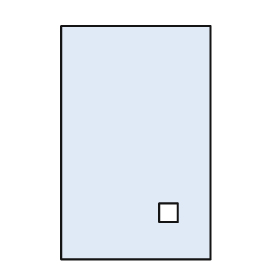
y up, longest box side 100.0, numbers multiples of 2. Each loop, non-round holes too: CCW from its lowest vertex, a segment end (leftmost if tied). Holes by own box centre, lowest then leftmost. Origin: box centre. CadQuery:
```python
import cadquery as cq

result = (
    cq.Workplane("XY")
    .moveTo(-32.0, -50.0)
    .lineTo(32.0, -50.0)
    .lineTo(32.0, 50.0)
    .lineTo(-32.0, 50.0)
    .close()
    .moveTo(10.0, -34.0)
    .lineTo(18.0, -34.0)
    .lineTo(18.0, -26.0)
    .lineTo(10.0, -26.0)
    .close()
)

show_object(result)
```